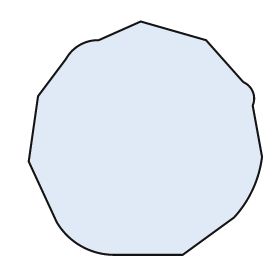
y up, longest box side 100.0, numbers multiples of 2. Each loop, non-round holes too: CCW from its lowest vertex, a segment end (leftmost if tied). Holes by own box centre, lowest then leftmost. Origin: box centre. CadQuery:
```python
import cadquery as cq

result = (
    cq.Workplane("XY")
    .moveTo(-14.0, -50.0)
    .lineTo(16.0, -50.0)
    .lineTo(38.0, -34.0)
    .threePointArc((46.0, -22.0), (50.0, -8.0))
    .lineTo(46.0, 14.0)
    .threePointArc((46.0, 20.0), (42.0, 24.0))
    .lineTo(26.0, 42.0)
    .lineTo(-2.0, 50.0)
    .lineTo(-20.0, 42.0)
    .threePointArc((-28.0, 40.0), (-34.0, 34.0))
    .lineTo(-46.0, 18.0)
    .lineTo(-50.0, -10.0)
    .lineTo(-38.0, -36.0)
    .threePointArc((-28.0, -46.0), (-14.0, -50.0))
    .close()
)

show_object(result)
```